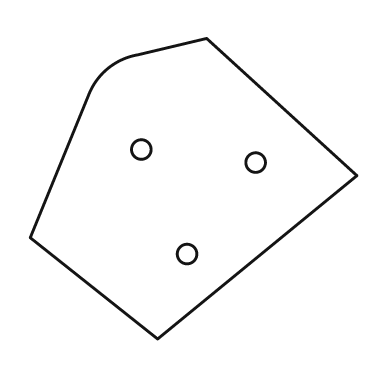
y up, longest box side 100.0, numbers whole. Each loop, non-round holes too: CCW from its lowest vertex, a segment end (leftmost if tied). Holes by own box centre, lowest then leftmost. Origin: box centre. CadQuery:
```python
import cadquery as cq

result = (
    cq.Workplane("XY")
    .moveTo(-11.0, -46.0)
    .lineTo(50.0, 4.0)
    .lineTo(4.0, 46.0)
    .lineTo(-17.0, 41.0)
    .threePointArc((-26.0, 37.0), (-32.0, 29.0))
    .lineTo(-50.0, -15.0)
    .close()
    .moveTo(-2.0, -20.0)
    .circle(3.0)
    .moveTo(19.0, 8.0)
    .circle(3.0)
    .moveTo(-16.0, 12.0)
    .circle(3.0)
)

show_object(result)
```